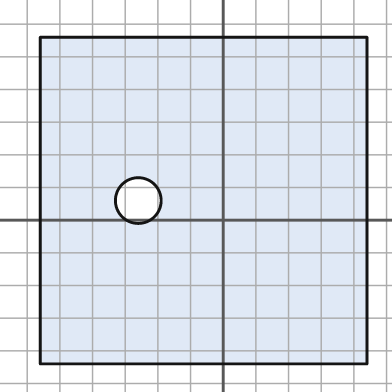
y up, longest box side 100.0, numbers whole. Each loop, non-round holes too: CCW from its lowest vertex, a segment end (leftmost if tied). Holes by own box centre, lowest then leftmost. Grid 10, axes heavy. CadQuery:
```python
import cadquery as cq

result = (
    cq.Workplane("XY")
    .moveTo(-56.0, -44.0)
    .lineTo(44.0, -44.0)
    .lineTo(44.0, 56.0)
    .lineTo(-56.0, 56.0)
    .close()
    .moveTo(-26.0, 6.0)
    .circle(7.0)
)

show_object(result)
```